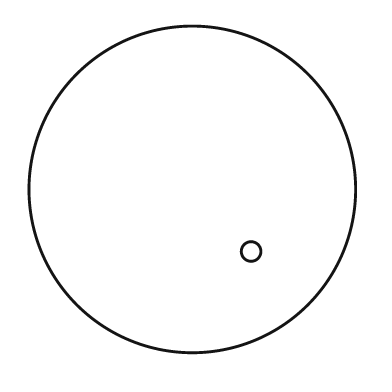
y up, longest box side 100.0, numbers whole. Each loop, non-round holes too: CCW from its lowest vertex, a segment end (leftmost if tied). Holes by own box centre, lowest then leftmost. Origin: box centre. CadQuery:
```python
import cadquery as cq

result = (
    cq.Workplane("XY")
    .moveTo(0.0, 0.0)
    .circle(50.0)
    .moveTo(18.0, -19.0)
    .circle(3.0)
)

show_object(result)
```